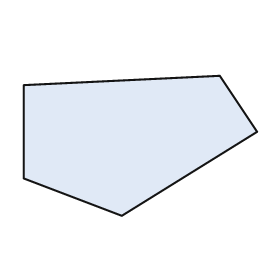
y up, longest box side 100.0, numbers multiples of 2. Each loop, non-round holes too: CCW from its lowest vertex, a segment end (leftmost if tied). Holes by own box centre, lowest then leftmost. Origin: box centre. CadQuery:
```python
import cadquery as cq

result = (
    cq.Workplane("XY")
    .moveTo(-8.0, -30.0)
    .lineTo(50.0, 6.0)
    .lineTo(34.0, 30.0)
    .lineTo(-50.0, 26.0)
    .lineTo(-50.0, -14.0)
    .close()
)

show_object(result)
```